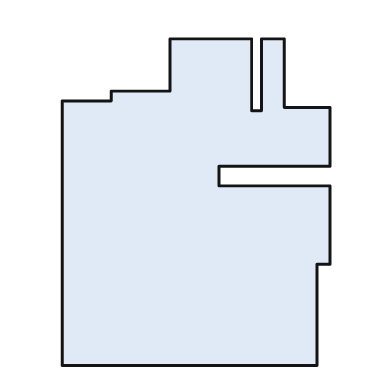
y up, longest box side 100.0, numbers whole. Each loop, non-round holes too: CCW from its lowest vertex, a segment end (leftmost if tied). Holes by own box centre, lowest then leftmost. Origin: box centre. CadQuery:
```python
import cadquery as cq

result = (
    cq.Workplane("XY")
    .moveTo(-41.0, -50.0)
    .lineTo(37.0, -50.0)
    .lineTo(37.0, -19.0)
    .lineTo(41.0, -19.0)
    .lineTo(41.0, 5.0)
    .lineTo(7.0, 5.0)
    .lineTo(7.0, 11.0)
    .lineTo(41.0, 11.0)
    .lineTo(41.0, 29.0)
    .lineTo(27.0, 29.0)
    .lineTo(27.0, 50.0)
    .lineTo(20.0, 50.0)
    .lineTo(20.0, 28.0)
    .lineTo(17.0, 28.0)
    .lineTo(17.0, 50.0)
    .lineTo(-8.0, 50.0)
    .lineTo(-8.0, 34.0)
    .lineTo(-26.0, 34.0)
    .lineTo(-26.0, 31.0)
    .lineTo(-41.0, 31.0)
    .close()
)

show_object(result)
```